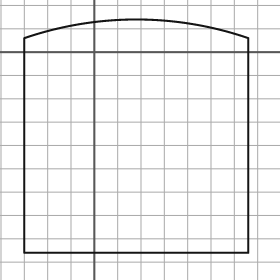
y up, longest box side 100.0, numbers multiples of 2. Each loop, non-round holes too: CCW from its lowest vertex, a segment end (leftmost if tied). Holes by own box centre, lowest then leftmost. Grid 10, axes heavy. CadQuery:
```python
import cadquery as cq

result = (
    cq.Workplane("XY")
    .moveTo(-30.0, -86.0)
    .lineTo(66.0, -86.0)
    .lineTo(66.0, 6.0)
    .threePointArc((18.0, 14.0), (-30.0, 6.0))
    .close()
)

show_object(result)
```